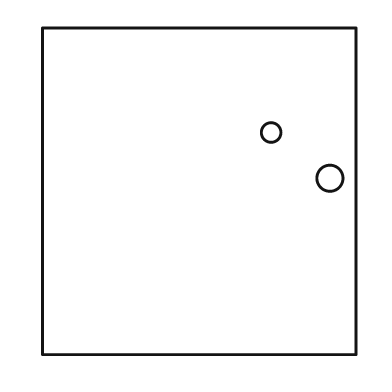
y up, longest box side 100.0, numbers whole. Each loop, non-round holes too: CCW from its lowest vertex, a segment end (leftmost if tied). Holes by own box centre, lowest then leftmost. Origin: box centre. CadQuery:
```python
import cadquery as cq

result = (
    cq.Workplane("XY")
    .moveTo(-48.0, -50.0)
    .lineTo(48.0, -50.0)
    .lineTo(48.0, 50.0)
    .lineTo(-48.0, 50.0)
    .close()
    .moveTo(40.0, 4.0)
    .circle(4.0)
    .moveTo(22.0, 18.0)
    .circle(3.0)
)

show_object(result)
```